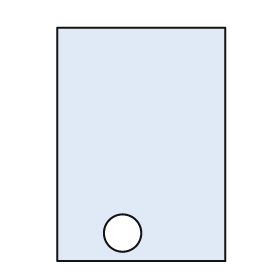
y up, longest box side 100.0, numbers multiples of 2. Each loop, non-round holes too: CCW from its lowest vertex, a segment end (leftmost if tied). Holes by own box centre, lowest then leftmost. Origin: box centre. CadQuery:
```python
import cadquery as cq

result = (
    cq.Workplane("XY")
    .moveTo(-36.0, -50.0)
    .lineTo(36.0, -50.0)
    .lineTo(36.0, 50.0)
    .lineTo(-36.0, 50.0)
    .close()
    .moveTo(-8.0, -38.0)
    .circle(8.0)
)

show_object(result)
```